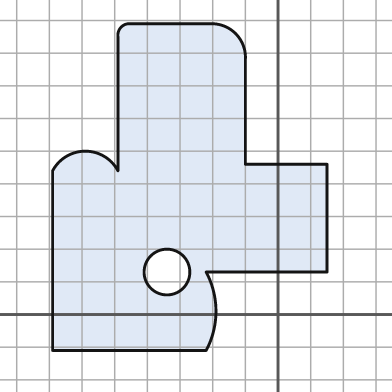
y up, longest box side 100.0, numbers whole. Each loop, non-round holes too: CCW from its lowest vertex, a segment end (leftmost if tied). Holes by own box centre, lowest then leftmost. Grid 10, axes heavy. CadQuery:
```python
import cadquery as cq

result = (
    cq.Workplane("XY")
    .moveTo(-69.0, -11.0)
    .lineTo(-22.0, -11.0)
    .threePointArc((-19.0, 1.0), (-22.0, 13.0))
    .lineTo(15.0, 13.0)
    .lineTo(15.0, 46.0)
    .lineTo(-10.0, 46.0)
    .lineTo(-10.0, 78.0)
    .threePointArc((-13.0, 86.0), (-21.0, 89.0))
    .lineTo(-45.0, 89.0)
    .threePointArc((-48.0, 88.0), (-49.0, 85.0))
    .lineTo(-49.0, 44.0)
    .threePointArc((-59.0, 50.0), (-69.0, 44.0))
    .close()
    .moveTo(-34.0, 13.0)
    .circle(7.0)
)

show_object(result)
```